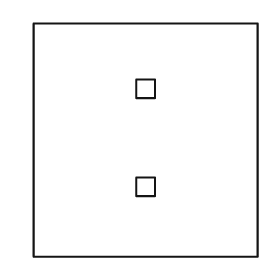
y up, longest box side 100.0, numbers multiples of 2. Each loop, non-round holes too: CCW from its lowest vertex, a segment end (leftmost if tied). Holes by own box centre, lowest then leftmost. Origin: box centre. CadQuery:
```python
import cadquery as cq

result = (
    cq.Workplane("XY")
    .moveTo(-48.0, -50.0)
    .lineTo(48.0, -50.0)
    .lineTo(48.0, 50.0)
    .lineTo(-48.0, 50.0)
    .close()
    .moveTo(-4.0, -24.0)
    .lineTo(4.0, -24.0)
    .lineTo(4.0, -16.0)
    .lineTo(-4.0, -16.0)
    .close()
    .moveTo(-4.0, 18.0)
    .lineTo(4.0, 18.0)
    .lineTo(4.0, 26.0)
    .lineTo(-4.0, 26.0)
    .close()
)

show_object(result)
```